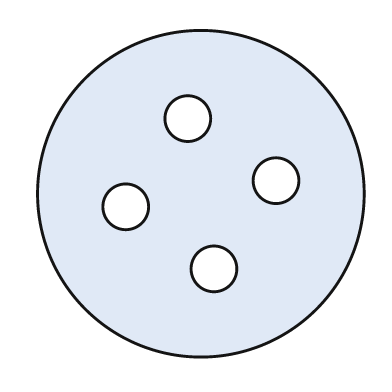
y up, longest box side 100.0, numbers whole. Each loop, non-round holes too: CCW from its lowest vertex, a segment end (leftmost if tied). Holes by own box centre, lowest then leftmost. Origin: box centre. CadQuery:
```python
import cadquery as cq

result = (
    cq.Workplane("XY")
    .moveTo(0.0, 0.0)
    .circle(50.0)
    .moveTo(4.0, -23.0)
    .circle(7.0)
    .moveTo(-23.0, -4.0)
    .circle(7.0)
    .moveTo(23.0, 4.0)
    .circle(7.0)
    .moveTo(-4.0, 23.0)
    .circle(7.0)
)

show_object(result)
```